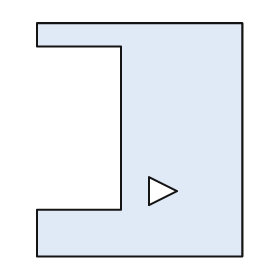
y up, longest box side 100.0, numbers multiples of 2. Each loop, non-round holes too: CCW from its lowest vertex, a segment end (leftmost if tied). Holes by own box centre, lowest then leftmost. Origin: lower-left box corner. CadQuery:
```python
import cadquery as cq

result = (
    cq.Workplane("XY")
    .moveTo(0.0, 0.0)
    .lineTo(88.0, 0.0)
    .lineTo(88.0, 100.0)
    .lineTo(0.0, 100.0)
    .lineTo(0.0, 90.0)
    .lineTo(36.0, 90.0)
    .lineTo(36.0, 20.0)
    .lineTo(0.0, 20.0)
    .close()
    .moveTo(48.0, 22.0)
    .lineTo(60.0, 28.0)
    .lineTo(48.0, 34.0)
    .close()
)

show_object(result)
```